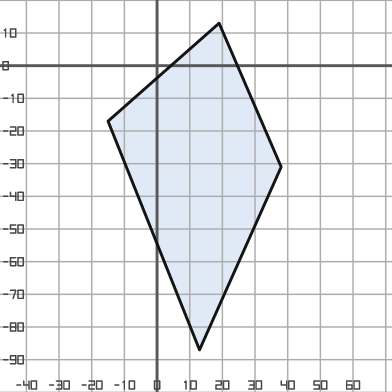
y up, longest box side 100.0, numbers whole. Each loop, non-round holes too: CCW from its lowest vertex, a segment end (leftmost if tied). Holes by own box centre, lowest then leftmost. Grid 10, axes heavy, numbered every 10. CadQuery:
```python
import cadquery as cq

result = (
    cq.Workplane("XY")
    .moveTo(13.0, -87.0)
    .lineTo(38.0, -31.0)
    .lineTo(19.0, 13.0)
    .lineTo(-15.0, -17.0)
    .close()
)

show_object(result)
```